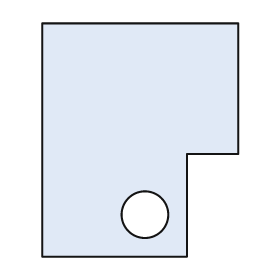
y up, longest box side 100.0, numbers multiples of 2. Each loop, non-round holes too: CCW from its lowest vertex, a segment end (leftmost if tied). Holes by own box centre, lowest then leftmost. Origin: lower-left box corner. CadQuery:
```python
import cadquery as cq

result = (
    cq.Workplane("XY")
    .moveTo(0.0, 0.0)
    .lineTo(62.0, 0.0)
    .lineTo(62.0, 44.0)
    .lineTo(84.0, 44.0)
    .lineTo(84.0, 100.0)
    .lineTo(0.0, 100.0)
    .close()
    .moveTo(44.0, 18.0)
    .circle(10.0)
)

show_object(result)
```